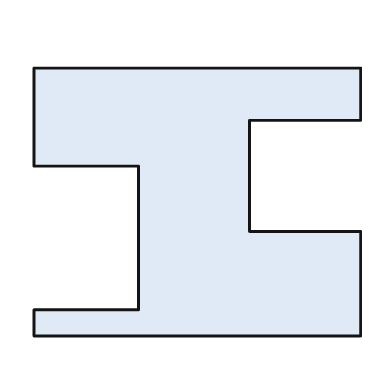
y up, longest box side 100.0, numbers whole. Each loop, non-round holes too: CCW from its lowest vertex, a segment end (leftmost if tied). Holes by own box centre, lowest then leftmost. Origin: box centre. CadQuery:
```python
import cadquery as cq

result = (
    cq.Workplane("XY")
    .moveTo(-50.0, -41.0)
    .lineTo(50.0, -41.0)
    .lineTo(50.0, -9.0)
    .lineTo(16.0, -9.0)
    .lineTo(16.0, 25.0)
    .lineTo(50.0, 25.0)
    .lineTo(50.0, 41.0)
    .lineTo(-50.0, 41.0)
    .lineTo(-50.0, 11.0)
    .lineTo(-18.0, 11.0)
    .lineTo(-18.0, -33.0)
    .lineTo(-50.0, -33.0)
    .close()
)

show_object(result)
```